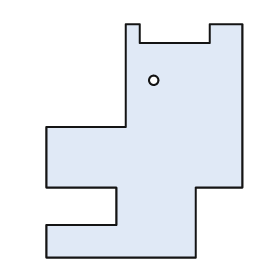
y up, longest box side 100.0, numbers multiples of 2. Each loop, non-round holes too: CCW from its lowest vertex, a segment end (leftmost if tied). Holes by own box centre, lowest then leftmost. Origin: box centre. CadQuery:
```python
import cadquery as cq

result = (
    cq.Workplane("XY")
    .moveTo(-42.0, -50.0)
    .lineTo(22.0, -50.0)
    .lineTo(22.0, -20.0)
    .lineTo(42.0, -20.0)
    .lineTo(42.0, 50.0)
    .lineTo(28.0, 50.0)
    .lineTo(28.0, 42.0)
    .lineTo(-2.0, 42.0)
    .lineTo(-2.0, 50.0)
    .lineTo(-8.0, 50.0)
    .lineTo(-8.0, 6.0)
    .lineTo(-42.0, 6.0)
    .lineTo(-42.0, -20.0)
    .lineTo(-12.0, -20.0)
    .lineTo(-12.0, -36.0)
    .lineTo(-42.0, -36.0)
    .close()
    .moveTo(4.0, 26.0)
    .circle(2.0)
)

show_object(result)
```